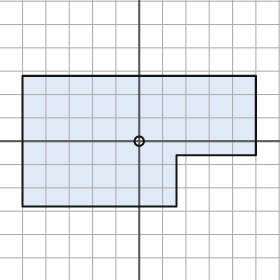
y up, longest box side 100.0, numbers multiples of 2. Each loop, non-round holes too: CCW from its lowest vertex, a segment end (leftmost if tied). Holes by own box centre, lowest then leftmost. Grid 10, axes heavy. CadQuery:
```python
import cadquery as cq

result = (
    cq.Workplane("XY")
    .moveTo(-50.0, -28.0)
    .lineTo(16.0, -28.0)
    .lineTo(16.0, -6.0)
    .lineTo(50.0, -6.0)
    .lineTo(50.0, 28.0)
    .lineTo(-50.0, 28.0)
    .close()
    .moveTo(0.0, 0.0)
    .circle(2.0)
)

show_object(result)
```